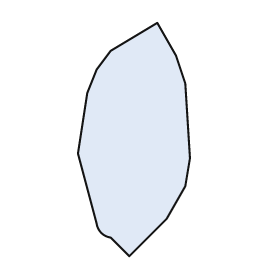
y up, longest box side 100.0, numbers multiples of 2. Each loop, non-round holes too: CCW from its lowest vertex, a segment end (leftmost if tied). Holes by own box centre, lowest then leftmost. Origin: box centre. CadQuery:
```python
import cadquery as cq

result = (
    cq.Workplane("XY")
    .moveTo(-2.0, -50.0)
    .lineTo(14.0, -34.0)
    .lineTo(22.0, -20.0)
    .lineTo(24.0, -8.0)
    .lineTo(22.0, 24.0)
    .lineTo(18.0, 36.0)
    .lineTo(10.0, 50.0)
    .lineTo(-10.0, 38.0)
    .lineTo(-16.0, 30.0)
    .lineTo(-20.0, 20.0)
    .lineTo(-24.0, -6.0)
    .lineTo(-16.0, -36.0)
    .threePointArc((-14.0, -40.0), (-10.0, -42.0))
    .close()
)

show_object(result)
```